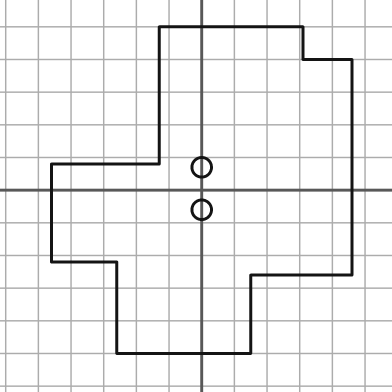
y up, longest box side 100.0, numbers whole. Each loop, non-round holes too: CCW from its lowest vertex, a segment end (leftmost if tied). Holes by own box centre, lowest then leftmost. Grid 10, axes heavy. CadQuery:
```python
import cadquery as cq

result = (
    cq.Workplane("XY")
    .moveTo(-26.0, -50.0)
    .lineTo(15.0, -50.0)
    .lineTo(15.0, -26.0)
    .lineTo(46.0, -26.0)
    .lineTo(46.0, 40.0)
    .lineTo(31.0, 40.0)
    .lineTo(31.0, 50.0)
    .lineTo(-13.0, 50.0)
    .lineTo(-13.0, 8.0)
    .lineTo(-46.0, 8.0)
    .lineTo(-46.0, -22.0)
    .lineTo(-26.0, -22.0)
    .close()
    .moveTo(0.0, -6.0)
    .circle(3.0)
    .moveTo(0.0, 7.0)
    .circle(3.0)
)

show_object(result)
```